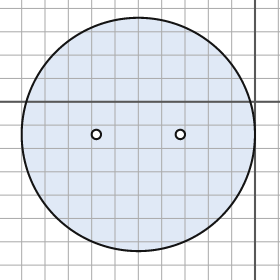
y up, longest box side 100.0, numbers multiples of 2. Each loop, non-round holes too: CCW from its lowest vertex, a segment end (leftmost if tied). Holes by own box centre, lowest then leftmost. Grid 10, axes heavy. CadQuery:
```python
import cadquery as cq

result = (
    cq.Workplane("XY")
    .moveTo(-50.0, -14.0)
    .circle(50.0)
    .moveTo(-68.0, -14.0)
    .circle(2.0)
    .moveTo(-32.0, -14.0)
    .circle(2.0)
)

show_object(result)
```